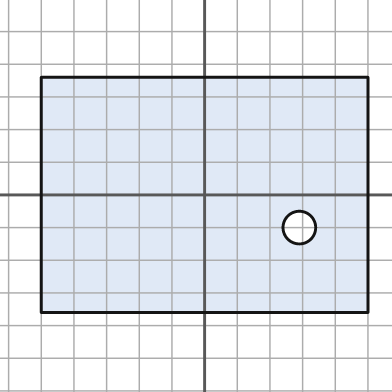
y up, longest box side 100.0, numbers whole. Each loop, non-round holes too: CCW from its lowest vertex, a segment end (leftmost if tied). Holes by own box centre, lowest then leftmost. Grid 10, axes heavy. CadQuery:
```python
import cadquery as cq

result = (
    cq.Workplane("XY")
    .moveTo(-50.0, -36.0)
    .lineTo(50.0, -36.0)
    .lineTo(50.0, 36.0)
    .lineTo(-50.0, 36.0)
    .close()
    .moveTo(29.0, -10.0)
    .circle(5.0)
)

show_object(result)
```